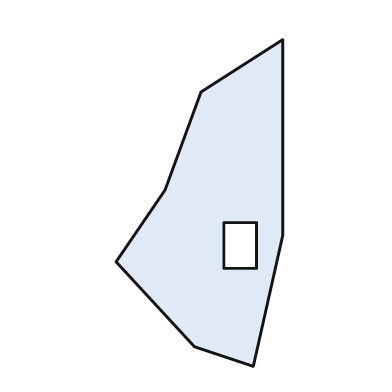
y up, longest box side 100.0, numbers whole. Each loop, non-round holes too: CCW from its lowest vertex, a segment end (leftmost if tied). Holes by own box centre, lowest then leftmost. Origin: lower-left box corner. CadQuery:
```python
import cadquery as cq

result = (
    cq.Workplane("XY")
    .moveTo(42.0, 0.0)
    .lineTo(51.0, 40.0)
    .lineTo(51.0, 100.0)
    .lineTo(26.0, 84.0)
    .lineTo(15.0, 54.0)
    .lineTo(0.0, 32.0)
    .lineTo(24.0, 6.0)
    .close()
    .moveTo(33.0, 30.0)
    .lineTo(43.0, 30.0)
    .lineTo(43.0, 44.0)
    .lineTo(33.0, 44.0)
    .close()
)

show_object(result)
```